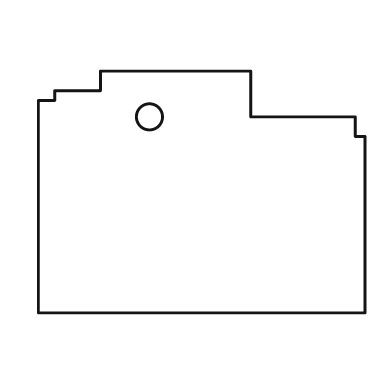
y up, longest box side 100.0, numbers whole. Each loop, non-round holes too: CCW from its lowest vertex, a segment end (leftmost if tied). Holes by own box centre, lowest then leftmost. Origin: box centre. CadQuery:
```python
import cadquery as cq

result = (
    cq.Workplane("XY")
    .moveTo(-50.0, -37.0)
    .lineTo(50.0, -37.0)
    .lineTo(50.0, 17.0)
    .lineTo(47.0, 17.0)
    .lineTo(47.0, 23.0)
    .lineTo(15.0, 23.0)
    .lineTo(15.0, 37.0)
    .lineTo(-31.0, 37.0)
    .lineTo(-31.0, 31.0)
    .lineTo(-45.0, 31.0)
    .lineTo(-45.0, 28.0)
    .lineTo(-50.0, 28.0)
    .close()
    .moveTo(-16.0, 23.0)
    .circle(4.0)
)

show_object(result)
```